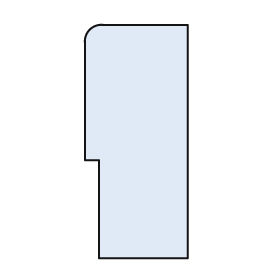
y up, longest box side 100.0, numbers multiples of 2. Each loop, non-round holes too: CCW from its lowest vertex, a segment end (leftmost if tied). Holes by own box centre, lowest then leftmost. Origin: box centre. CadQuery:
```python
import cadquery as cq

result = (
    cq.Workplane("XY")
    .moveTo(-16.0, -50.0)
    .lineTo(22.0, -50.0)
    .lineTo(22.0, 50.0)
    .lineTo(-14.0, 50.0)
    .threePointArc((-20.0, 48.0), (-22.0, 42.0))
    .lineTo(-22.0, -8.0)
    .lineTo(-16.0, -8.0)
    .close()
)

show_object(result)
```